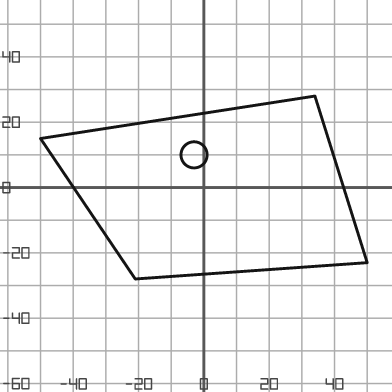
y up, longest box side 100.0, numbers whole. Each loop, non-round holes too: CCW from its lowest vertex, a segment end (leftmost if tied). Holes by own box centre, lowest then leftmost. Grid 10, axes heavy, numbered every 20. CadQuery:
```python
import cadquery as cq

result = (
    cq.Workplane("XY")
    .moveTo(-21.0, -28.0)
    .lineTo(50.0, -23.0)
    .lineTo(34.0, 28.0)
    .lineTo(-50.0, 15.0)
    .close()
    .moveTo(-3.0, 10.0)
    .circle(4.0)
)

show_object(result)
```